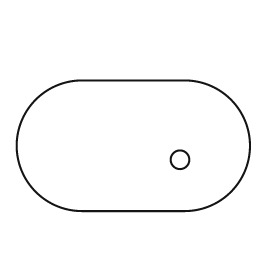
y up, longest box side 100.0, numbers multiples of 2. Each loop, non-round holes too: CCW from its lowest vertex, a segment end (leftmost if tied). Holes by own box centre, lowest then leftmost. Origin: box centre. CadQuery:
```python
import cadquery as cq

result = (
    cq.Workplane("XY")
    .moveTo(-22.0, -28.0)
    .lineTo(22.0, -28.0)
    .threePointArc((50.0, 0.0), (22.0, 28.0))
    .lineTo(-22.0, 28.0)
    .threePointArc((-50.0, 0.0), (-22.0, -28.0))
    .close()
    .moveTo(20.0, -6.0)
    .circle(4.0)
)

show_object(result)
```